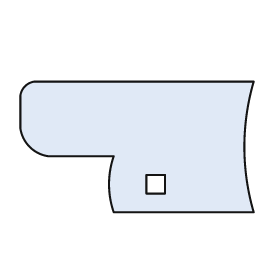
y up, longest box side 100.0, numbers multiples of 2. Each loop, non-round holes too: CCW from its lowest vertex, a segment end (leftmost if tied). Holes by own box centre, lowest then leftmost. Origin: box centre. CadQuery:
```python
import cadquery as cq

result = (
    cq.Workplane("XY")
    .moveTo(-10.0, -28.0)
    .lineTo(50.0, -28.0)
    .threePointArc((46.0, 0.0), (50.0, 28.0))
    .lineTo(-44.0, 28.0)
    .threePointArc((-48.0, 26.0), (-50.0, 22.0))
    .lineTo(-50.0, 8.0)
    .threePointArc((-46.0, 0.0), (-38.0, -4.0))
    .lineTo(-10.0, -4.0)
    .threePointArc((-12.0, -16.0), (-10.0, -28.0))
    .close()
    .moveTo(4.0, -20.0)
    .lineTo(12.0, -20.0)
    .lineTo(12.0, -12.0)
    .lineTo(4.0, -12.0)
    .close()
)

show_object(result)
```